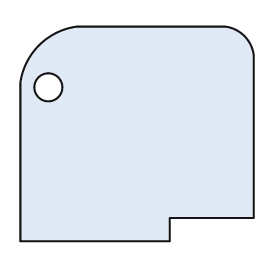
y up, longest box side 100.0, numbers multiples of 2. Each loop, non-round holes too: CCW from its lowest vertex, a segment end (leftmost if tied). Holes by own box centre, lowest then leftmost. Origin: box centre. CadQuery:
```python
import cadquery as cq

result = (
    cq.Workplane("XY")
    .moveTo(-50.0, -46.0)
    .lineTo(14.0, -46.0)
    .lineTo(14.0, -36.0)
    .lineTo(50.0, -36.0)
    .lineTo(50.0, 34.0)
    .threePointArc((46.0, 42.0), (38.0, 46.0))
    .lineTo(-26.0, 46.0)
    .threePointArc((-42.0, 38.0), (-50.0, 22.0))
    .close()
    .moveTo(-38.0, 20.0)
    .circle(6.0)
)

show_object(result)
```